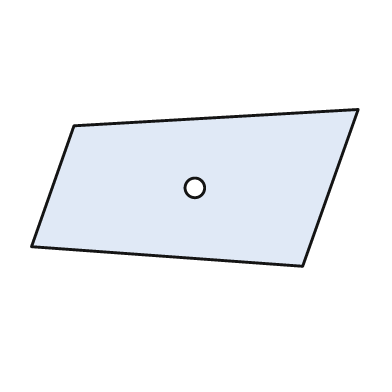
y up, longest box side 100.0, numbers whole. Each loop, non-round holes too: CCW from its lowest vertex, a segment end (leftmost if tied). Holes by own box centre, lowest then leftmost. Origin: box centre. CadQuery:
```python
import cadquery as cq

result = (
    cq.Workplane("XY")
    .moveTo(33.0, -24.0)
    .lineTo(50.0, 24.0)
    .lineTo(-37.0, 19.0)
    .lineTo(-50.0, -18.0)
    .close()
    .moveTo(0.0, 0.0)
    .circle(3.0)
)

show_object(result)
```